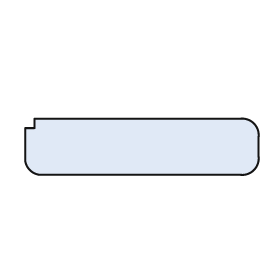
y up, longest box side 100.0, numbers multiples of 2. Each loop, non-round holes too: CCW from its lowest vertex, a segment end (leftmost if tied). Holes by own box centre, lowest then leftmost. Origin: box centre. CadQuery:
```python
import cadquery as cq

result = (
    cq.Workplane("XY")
    .moveTo(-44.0, -12.0)
    .lineTo(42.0, -12.0)
    .threePointArc((48.0, -10.0), (50.0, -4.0))
    .lineTo(50.0, 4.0)
    .threePointArc((48.0, 10.0), (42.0, 12.0))
    .lineTo(-46.0, 12.0)
    .lineTo(-46.0, 8.0)
    .lineTo(-50.0, 8.0)
    .lineTo(-50.0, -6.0)
    .threePointArc((-48.0, -10.0), (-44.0, -12.0))
    .close()
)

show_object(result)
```